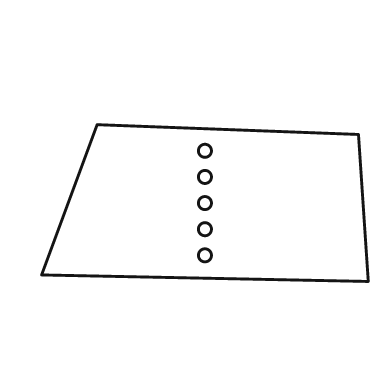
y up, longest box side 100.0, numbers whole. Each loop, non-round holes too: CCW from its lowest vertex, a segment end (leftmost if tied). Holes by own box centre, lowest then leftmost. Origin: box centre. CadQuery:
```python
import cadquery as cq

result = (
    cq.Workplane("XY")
    .moveTo(50.0, -24.0)
    .lineTo(47.0, 21.0)
    .lineTo(-33.0, 24.0)
    .lineTo(-50.0, -22.0)
    .close()
    .moveTo(0.0, -16.0)
    .circle(2.0)
    .moveTo(0.0, -8.0)
    .circle(2.0)
    .moveTo(0.0, 0.0)
    .circle(2.0)
    .moveTo(0.0, 8.0)
    .circle(2.0)
    .moveTo(0.0, 16.0)
    .circle(2.0)
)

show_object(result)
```